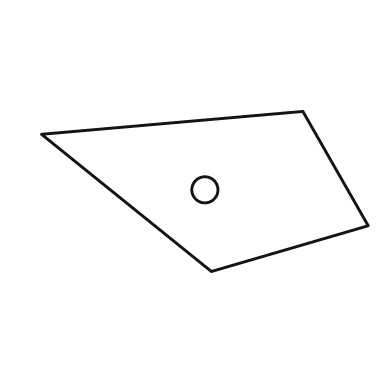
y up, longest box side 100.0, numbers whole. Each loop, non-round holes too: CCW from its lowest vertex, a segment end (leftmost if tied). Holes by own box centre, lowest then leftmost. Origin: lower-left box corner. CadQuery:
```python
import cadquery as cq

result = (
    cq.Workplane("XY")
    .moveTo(52.0, 0.0)
    .lineTo(100.0, 14.0)
    .lineTo(80.0, 49.0)
    .lineTo(0.0, 42.0)
    .close()
    .moveTo(50.0, 25.0)
    .circle(4.0)
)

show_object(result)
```